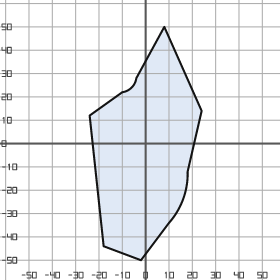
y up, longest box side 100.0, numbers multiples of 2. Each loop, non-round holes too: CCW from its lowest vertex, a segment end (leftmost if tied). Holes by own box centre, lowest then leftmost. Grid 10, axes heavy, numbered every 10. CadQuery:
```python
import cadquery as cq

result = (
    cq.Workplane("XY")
    .moveTo(-2.0, -50.0)
    .lineTo(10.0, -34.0)
    .threePointArc((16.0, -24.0), (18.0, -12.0))
    .lineTo(24.0, 14.0)
    .lineTo(8.0, 50.0)
    .lineTo(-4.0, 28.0)
    .threePointArc((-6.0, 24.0), (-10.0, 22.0))
    .lineTo(-24.0, 12.0)
    .lineTo(-18.0, -44.0)
    .close()
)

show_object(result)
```